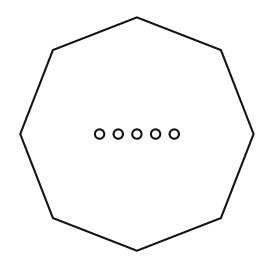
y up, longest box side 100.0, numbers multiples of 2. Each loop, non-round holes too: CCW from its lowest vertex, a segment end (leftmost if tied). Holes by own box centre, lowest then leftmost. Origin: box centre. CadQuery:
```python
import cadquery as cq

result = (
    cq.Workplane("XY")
    .moveTo(0.0, -50.0)
    .lineTo(36.0, -36.0)
    .lineTo(50.0, 0.0)
    .lineTo(36.0, 36.0)
    .lineTo(0.0, 50.0)
    .lineTo(-36.0, 36.0)
    .lineTo(-50.0, 0.0)
    .lineTo(-36.0, -36.0)
    .close()
    .moveTo(-16.0, 0.0)
    .circle(2.0)
    .moveTo(-8.0, 0.0)
    .circle(2.0)
    .moveTo(0.0, 0.0)
    .circle(2.0)
    .moveTo(8.0, 0.0)
    .circle(2.0)
    .moveTo(16.0, 0.0)
    .circle(2.0)
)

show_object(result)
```